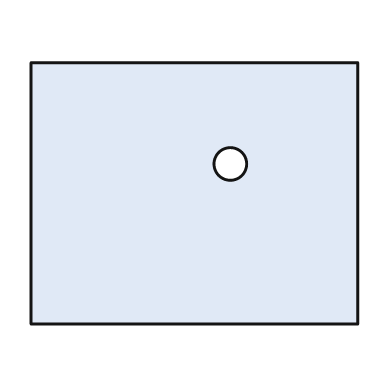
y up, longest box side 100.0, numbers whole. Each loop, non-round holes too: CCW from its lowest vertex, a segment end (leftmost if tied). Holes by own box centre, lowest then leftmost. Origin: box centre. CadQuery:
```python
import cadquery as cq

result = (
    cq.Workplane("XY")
    .moveTo(-50.0, -40.0)
    .lineTo(50.0, -40.0)
    .lineTo(50.0, 40.0)
    .lineTo(-50.0, 40.0)
    .close()
    .moveTo(11.0, 9.0)
    .circle(5.0)
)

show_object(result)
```